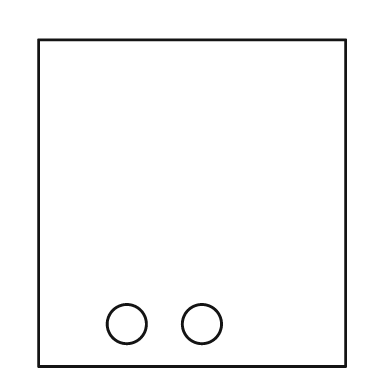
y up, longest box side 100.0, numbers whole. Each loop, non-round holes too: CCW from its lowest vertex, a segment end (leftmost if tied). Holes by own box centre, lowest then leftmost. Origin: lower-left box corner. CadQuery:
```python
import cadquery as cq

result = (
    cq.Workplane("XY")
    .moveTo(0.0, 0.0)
    .lineTo(94.0, 0.0)
    .lineTo(94.0, 100.0)
    .lineTo(0.0, 100.0)
    .close()
    .moveTo(27.0, 13.0)
    .circle(6.0)
    .moveTo(50.0, 13.0)
    .circle(6.0)
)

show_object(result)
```